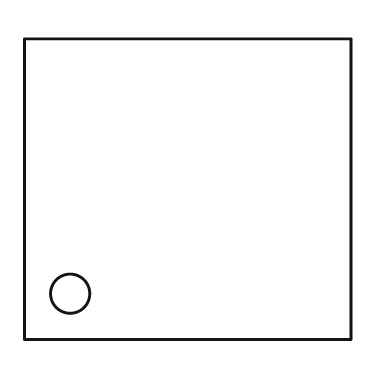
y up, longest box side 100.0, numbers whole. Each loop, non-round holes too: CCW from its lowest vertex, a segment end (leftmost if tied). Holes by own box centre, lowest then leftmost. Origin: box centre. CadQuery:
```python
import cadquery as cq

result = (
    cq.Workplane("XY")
    .moveTo(-50.0, -46.0)
    .lineTo(50.0, -46.0)
    .lineTo(50.0, 46.0)
    .lineTo(-50.0, 46.0)
    .close()
    .moveTo(-36.0, -32.0)
    .circle(6.0)
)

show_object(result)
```